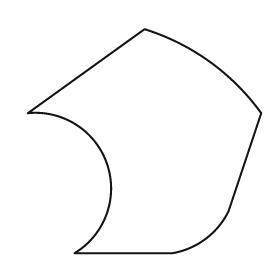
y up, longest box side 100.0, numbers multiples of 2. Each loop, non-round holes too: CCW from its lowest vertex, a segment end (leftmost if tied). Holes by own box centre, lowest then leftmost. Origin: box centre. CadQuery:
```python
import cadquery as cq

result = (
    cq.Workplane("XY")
    .moveTo(-30.0, -48.0)
    .lineTo(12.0, -48.0)
    .threePointArc((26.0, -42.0), (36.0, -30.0))
    .lineTo(50.0, 12.0)
    .threePointArc((28.0, 34.0), (0.0, 48.0))
    .lineTo(-50.0, 12.0)
    .threePointArc((-16.0, -10.0), (-30.0, -48.0))
    .close()
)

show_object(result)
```